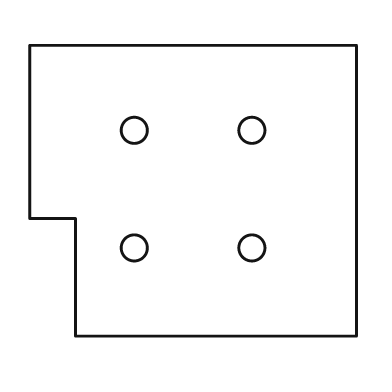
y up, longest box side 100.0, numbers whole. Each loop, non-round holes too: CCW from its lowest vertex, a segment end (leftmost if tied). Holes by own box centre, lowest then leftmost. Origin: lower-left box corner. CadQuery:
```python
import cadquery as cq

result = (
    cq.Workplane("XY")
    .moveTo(14.0, 0.0)
    .lineTo(100.0, 0.0)
    .lineTo(100.0, 89.0)
    .lineTo(0.0, 89.0)
    .lineTo(0.0, 36.0)
    .lineTo(14.0, 36.0)
    .close()
    .moveTo(32.0, 27.0)
    .circle(4.0)
    .moveTo(68.0, 27.0)
    .circle(4.0)
    .moveTo(32.0, 63.0)
    .circle(4.0)
    .moveTo(68.0, 63.0)
    .circle(4.0)
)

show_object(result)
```